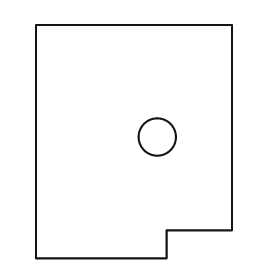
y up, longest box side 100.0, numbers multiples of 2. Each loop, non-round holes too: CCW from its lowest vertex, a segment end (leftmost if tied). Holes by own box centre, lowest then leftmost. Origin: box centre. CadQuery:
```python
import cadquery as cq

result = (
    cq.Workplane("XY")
    .moveTo(-42.0, -50.0)
    .lineTo(14.0, -50.0)
    .lineTo(14.0, -38.0)
    .lineTo(42.0, -38.0)
    .lineTo(42.0, 50.0)
    .lineTo(-42.0, 50.0)
    .close()
    .moveTo(10.0, 2.0)
    .circle(8.0)
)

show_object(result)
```